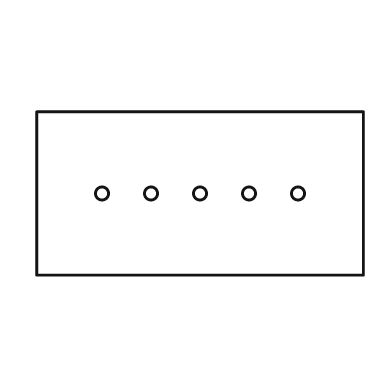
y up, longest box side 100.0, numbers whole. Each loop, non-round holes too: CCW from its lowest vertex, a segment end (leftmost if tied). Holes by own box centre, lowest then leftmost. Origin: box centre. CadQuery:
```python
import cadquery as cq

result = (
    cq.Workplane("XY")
    .moveTo(-50.0, -25.0)
    .lineTo(50.0, -25.0)
    .lineTo(50.0, 25.0)
    .lineTo(-50.0, 25.0)
    .close()
    .moveTo(-30.0, 0.0)
    .circle(2.0)
    .moveTo(-15.0, 0.0)
    .circle(2.0)
    .moveTo(0.0, 0.0)
    .circle(2.0)
    .moveTo(15.0, 0.0)
    .circle(2.0)
    .moveTo(30.0, 0.0)
    .circle(2.0)
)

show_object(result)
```